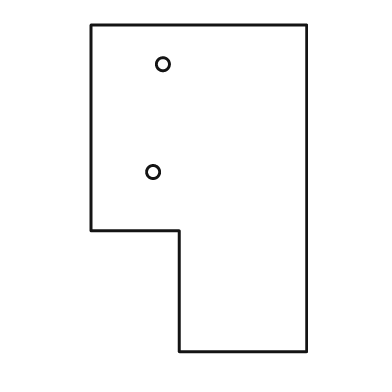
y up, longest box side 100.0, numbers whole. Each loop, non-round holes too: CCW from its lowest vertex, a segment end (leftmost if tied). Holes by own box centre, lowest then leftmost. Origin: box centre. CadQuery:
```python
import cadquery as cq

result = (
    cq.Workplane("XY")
    .moveTo(-6.0, -50.0)
    .lineTo(33.0, -50.0)
    .lineTo(33.0, 50.0)
    .lineTo(-33.0, 50.0)
    .lineTo(-33.0, -13.0)
    .lineTo(-6.0, -13.0)
    .close()
    .moveTo(-14.0, 5.0)
    .circle(2.0)
    .moveTo(-11.0, 38.0)
    .circle(2.0)
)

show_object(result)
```